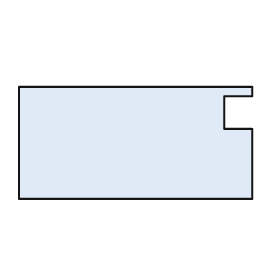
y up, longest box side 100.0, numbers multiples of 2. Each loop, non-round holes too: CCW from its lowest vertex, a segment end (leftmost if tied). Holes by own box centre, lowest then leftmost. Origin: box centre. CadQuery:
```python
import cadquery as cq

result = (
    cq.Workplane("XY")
    .moveTo(-50.0, -24.0)
    .lineTo(50.0, -24.0)
    .lineTo(50.0, 6.0)
    .lineTo(38.0, 6.0)
    .lineTo(38.0, 20.0)
    .lineTo(50.0, 20.0)
    .lineTo(50.0, 24.0)
    .lineTo(-50.0, 24.0)
    .close()
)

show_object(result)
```